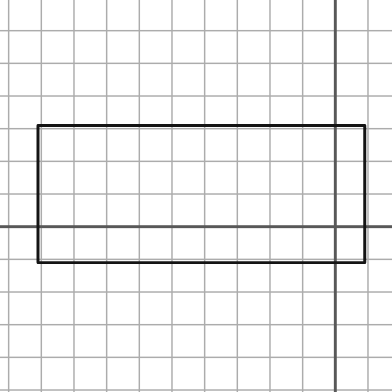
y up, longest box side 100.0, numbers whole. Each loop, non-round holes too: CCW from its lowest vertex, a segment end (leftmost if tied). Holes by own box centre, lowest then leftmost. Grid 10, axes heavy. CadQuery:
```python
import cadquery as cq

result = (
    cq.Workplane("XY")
    .moveTo(-91.0, -11.0)
    .lineTo(9.0, -11.0)
    .lineTo(9.0, 31.0)
    .lineTo(-91.0, 31.0)
    .close()
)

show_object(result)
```